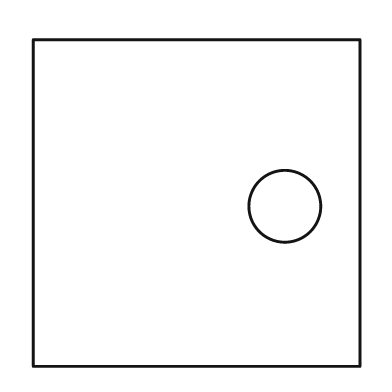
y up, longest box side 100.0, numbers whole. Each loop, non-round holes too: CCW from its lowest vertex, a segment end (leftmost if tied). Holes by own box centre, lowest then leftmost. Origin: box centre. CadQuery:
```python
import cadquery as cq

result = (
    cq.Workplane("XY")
    .moveTo(-50.0, -50.0)
    .lineTo(50.0, -50.0)
    .lineTo(50.0, 50.0)
    .lineTo(-50.0, 50.0)
    .close()
    .moveTo(27.0, -1.0)
    .circle(11.0)
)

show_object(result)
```